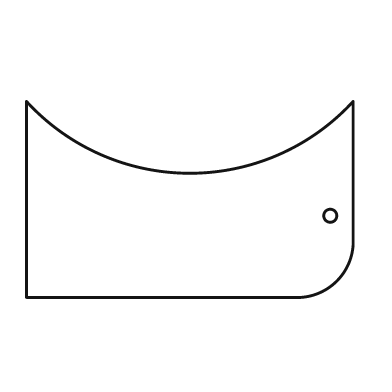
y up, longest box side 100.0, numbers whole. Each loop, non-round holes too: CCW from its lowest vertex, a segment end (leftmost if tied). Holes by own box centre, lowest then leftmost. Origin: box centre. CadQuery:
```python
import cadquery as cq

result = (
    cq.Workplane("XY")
    .moveTo(-50.0, -30.0)
    .lineTo(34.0, -30.0)
    .threePointArc((45.0, -25.0), (50.0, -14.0))
    .lineTo(50.0, 30.0)
    .threePointArc((0.0, 8.0), (-50.0, 30.0))
    .close()
    .moveTo(43.0, -5.0)
    .circle(2.0)
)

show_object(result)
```